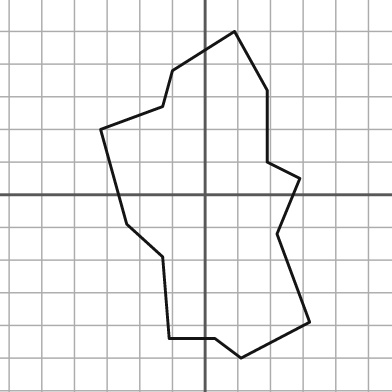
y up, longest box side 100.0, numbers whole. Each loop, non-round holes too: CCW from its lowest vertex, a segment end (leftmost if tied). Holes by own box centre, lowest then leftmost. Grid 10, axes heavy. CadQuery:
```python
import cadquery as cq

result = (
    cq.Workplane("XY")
    .moveTo(11.0, -50.0)
    .lineTo(32.0, -39.0)
    .lineTo(22.0, -12.0)
    .lineTo(29.0, 5.0)
    .lineTo(19.0, 10.0)
    .lineTo(19.0, 32.0)
    .lineTo(9.0, 50.0)
    .lineTo(-10.0, 38.0)
    .lineTo(-13.0, 27.0)
    .lineTo(-32.0, 20.0)
    .lineTo(-24.0, -9.0)
    .lineTo(-13.0, -19.0)
    .lineTo(-11.0, -44.0)
    .lineTo(3.0, -44.0)
    .close()
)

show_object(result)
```